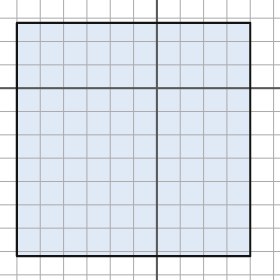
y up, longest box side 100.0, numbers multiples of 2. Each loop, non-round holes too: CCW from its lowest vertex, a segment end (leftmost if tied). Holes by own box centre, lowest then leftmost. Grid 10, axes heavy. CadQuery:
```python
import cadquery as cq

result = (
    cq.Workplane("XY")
    .moveTo(-60.0, -72.0)
    .lineTo(40.0, -72.0)
    .lineTo(40.0, 28.0)
    .lineTo(-60.0, 28.0)
    .close()
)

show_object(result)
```